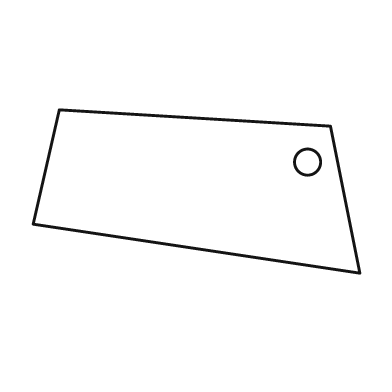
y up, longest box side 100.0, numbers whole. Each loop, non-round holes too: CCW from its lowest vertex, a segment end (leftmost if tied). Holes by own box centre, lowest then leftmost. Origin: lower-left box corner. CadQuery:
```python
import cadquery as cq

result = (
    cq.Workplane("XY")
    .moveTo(100.0, 0.0)
    .lineTo(91.0, 45.0)
    .lineTo(8.0, 50.0)
    .lineTo(0.0, 15.0)
    .close()
    .moveTo(84.0, 34.0)
    .circle(4.0)
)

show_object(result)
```